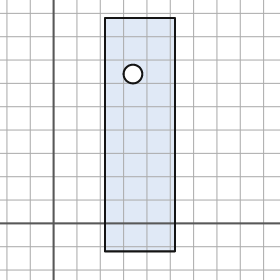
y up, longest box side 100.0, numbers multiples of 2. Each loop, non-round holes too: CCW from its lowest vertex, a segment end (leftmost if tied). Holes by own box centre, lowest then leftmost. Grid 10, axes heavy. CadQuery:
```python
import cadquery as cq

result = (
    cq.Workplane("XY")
    .moveTo(22.0, -12.0)
    .lineTo(52.0, -12.0)
    .lineTo(52.0, 88.0)
    .lineTo(22.0, 88.0)
    .close()
    .moveTo(34.0, 64.0)
    .circle(4.0)
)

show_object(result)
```